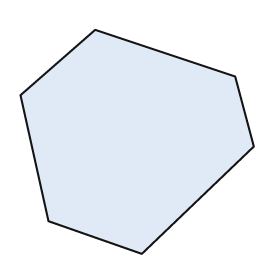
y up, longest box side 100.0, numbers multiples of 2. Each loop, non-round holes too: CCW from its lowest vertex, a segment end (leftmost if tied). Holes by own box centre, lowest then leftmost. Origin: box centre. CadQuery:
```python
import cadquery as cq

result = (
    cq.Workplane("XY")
    .moveTo(2.0, -48.0)
    .lineTo(50.0, -2.0)
    .lineTo(42.0, 28.0)
    .lineTo(-18.0, 48.0)
    .lineTo(-50.0, 20.0)
    .lineTo(-38.0, -34.0)
    .close()
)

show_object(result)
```